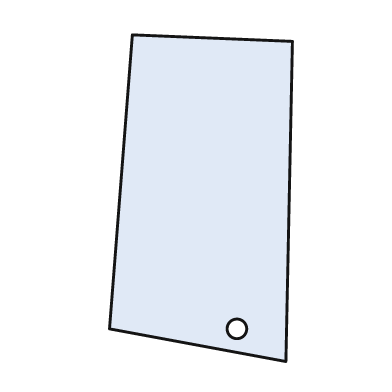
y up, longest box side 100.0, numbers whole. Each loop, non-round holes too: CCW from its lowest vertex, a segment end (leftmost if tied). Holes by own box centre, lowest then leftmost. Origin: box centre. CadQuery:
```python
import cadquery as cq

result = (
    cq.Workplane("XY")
    .moveTo(26.0, -50.0)
    .lineTo(28.0, 48.0)
    .lineTo(-21.0, 50.0)
    .lineTo(-28.0, -40.0)
    .close()
    .moveTo(11.0, -40.0)
    .circle(3.0)
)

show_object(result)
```